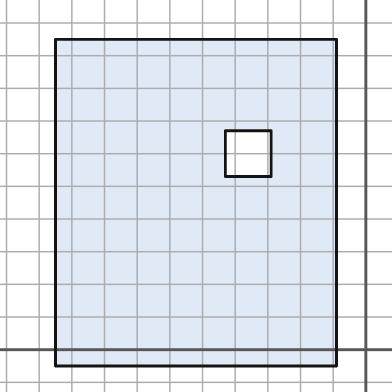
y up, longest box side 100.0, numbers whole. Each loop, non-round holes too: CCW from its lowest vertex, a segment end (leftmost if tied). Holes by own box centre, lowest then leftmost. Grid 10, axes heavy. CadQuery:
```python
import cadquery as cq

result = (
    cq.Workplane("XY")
    .moveTo(-95.0, -5.0)
    .lineTo(-9.0, -5.0)
    .lineTo(-9.0, 95.0)
    .lineTo(-95.0, 95.0)
    .close()
    .moveTo(-43.0, 53.0)
    .lineTo(-29.0, 53.0)
    .lineTo(-29.0, 67.0)
    .lineTo(-43.0, 67.0)
    .close()
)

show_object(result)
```